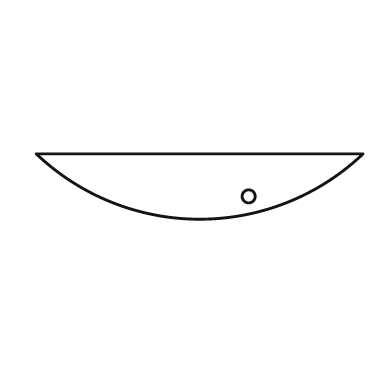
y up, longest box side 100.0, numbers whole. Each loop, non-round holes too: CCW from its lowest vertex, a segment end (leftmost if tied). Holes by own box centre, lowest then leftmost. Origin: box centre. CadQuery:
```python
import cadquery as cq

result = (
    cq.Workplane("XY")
    .moveTo(-50.0, 10.0)
    .threePointArc((0.0, -10.0), (50.0, 10.0))
    .close()
    .moveTo(15.0, -3.0)
    .circle(2.0)
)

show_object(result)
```